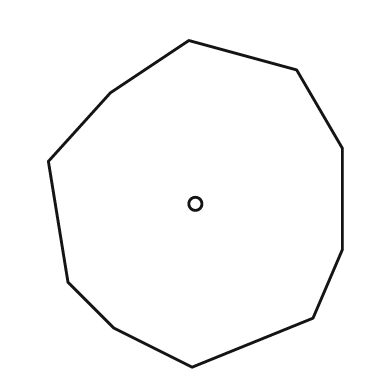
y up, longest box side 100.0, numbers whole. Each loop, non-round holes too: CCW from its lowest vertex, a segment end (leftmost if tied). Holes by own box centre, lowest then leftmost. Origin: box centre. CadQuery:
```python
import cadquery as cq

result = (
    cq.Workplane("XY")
    .moveTo(-1.0, -50.0)
    .lineTo(36.0, -35.0)
    .lineTo(45.0, -14.0)
    .lineTo(45.0, 17.0)
    .lineTo(31.0, 41.0)
    .lineTo(-2.0, 50.0)
    .lineTo(-26.0, 34.0)
    .lineTo(-45.0, 13.0)
    .lineTo(-39.0, -24.0)
    .lineTo(-25.0, -38.0)
    .close()
    .moveTo(0.0, 0.0)
    .circle(2.0)
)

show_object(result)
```